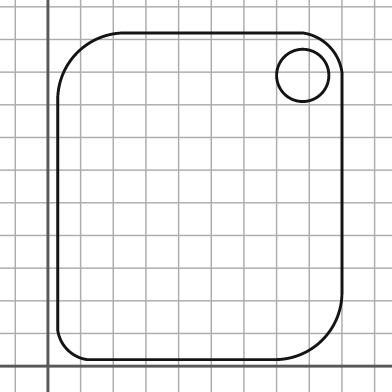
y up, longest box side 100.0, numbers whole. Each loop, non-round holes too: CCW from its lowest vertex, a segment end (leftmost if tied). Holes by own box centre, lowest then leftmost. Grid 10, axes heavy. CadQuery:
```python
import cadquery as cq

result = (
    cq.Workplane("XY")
    .moveTo(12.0, 2.0)
    .lineTo(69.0, 2.0)
    .threePointArc((84.0, 8.0), (90.0, 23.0))
    .lineTo(90.0, 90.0)
    .threePointArc((86.0, 98.0), (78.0, 102.0))
    .lineTo(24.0, 102.0)
    .threePointArc((9.0, 96.0), (3.0, 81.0))
    .lineTo(3.0, 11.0)
    .threePointArc((6.0, 5.0), (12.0, 2.0))
    .close()
    .moveTo(78.0, 89.0)
    .circle(8.0)
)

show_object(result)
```